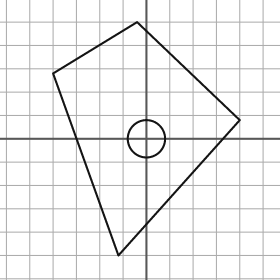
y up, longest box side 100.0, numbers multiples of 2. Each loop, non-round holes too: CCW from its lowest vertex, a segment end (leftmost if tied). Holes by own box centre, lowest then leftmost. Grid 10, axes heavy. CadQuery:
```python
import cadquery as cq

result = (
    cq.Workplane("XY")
    .moveTo(-12.0, -50.0)
    .lineTo(40.0, 8.0)
    .lineTo(-4.0, 50.0)
    .lineTo(-40.0, 28.0)
    .close()
    .moveTo(0.0, 0.0)
    .circle(8.0)
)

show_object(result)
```